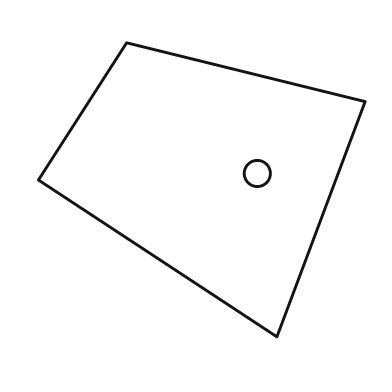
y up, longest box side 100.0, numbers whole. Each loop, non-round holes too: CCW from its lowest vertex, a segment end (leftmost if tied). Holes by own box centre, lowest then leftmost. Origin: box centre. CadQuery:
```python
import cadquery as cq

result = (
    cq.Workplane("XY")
    .moveTo(23.0, -45.0)
    .lineTo(50.0, 27.0)
    .lineTo(-23.0, 45.0)
    .lineTo(-50.0, 3.0)
    .close()
    .moveTo(17.0, 5.0)
    .circle(4.0)
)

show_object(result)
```